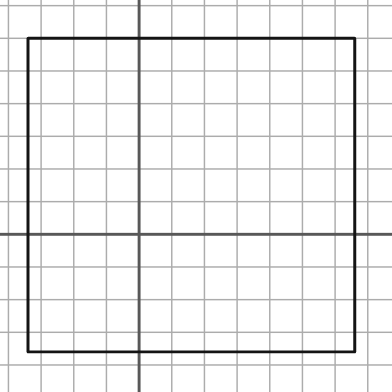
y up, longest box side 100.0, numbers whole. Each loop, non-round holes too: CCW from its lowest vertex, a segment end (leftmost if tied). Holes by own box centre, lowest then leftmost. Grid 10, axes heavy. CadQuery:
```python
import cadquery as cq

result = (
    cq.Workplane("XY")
    .moveTo(-34.0, -36.0)
    .lineTo(66.0, -36.0)
    .lineTo(66.0, 60.0)
    .lineTo(-34.0, 60.0)
    .close()
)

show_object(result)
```